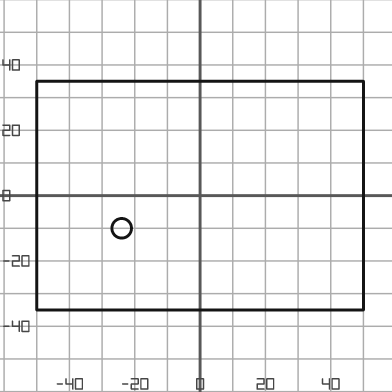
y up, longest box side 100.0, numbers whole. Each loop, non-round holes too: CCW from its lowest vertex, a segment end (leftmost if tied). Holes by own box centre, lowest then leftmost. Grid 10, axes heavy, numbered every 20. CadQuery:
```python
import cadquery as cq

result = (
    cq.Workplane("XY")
    .moveTo(-50.0, -35.0)
    .lineTo(50.0, -35.0)
    .lineTo(50.0, 35.0)
    .lineTo(-50.0, 35.0)
    .close()
    .moveTo(-24.0, -10.0)
    .circle(3.0)
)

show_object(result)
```